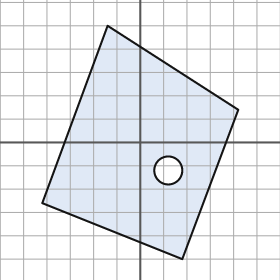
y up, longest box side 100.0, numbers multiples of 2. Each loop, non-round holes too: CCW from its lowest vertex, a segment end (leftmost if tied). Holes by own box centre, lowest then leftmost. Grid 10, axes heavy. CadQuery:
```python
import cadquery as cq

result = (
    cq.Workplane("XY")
    .moveTo(18.0, -50.0)
    .lineTo(42.0, 14.0)
    .lineTo(-14.0, 50.0)
    .lineTo(-42.0, -26.0)
    .close()
    .moveTo(12.0, -12.0)
    .circle(6.0)
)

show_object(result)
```